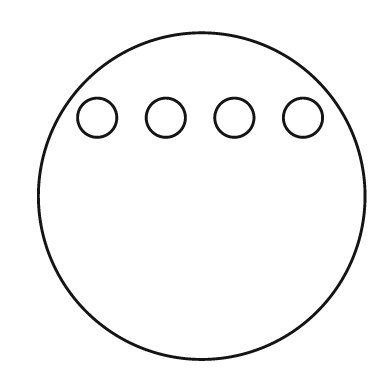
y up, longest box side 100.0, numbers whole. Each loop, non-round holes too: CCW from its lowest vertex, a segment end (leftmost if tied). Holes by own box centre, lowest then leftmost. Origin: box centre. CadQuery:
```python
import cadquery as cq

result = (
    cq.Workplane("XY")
    .moveTo(0.0, 0.0)
    .circle(50.0)
    .moveTo(-32.0, 24.0)
    .circle(6.0)
    .moveTo(-11.0, 24.0)
    .circle(6.0)
    .moveTo(10.0, 24.0)
    .circle(6.0)
    .moveTo(31.0, 24.0)
    .circle(6.0)
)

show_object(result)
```